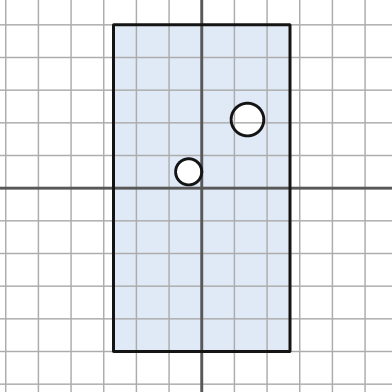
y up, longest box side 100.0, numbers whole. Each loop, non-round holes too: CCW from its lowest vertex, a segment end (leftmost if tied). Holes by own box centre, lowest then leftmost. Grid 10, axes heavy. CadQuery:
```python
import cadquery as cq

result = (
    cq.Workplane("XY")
    .moveTo(-27.0, -50.0)
    .lineTo(27.0, -50.0)
    .lineTo(27.0, 50.0)
    .lineTo(-27.0, 50.0)
    .close()
    .moveTo(-4.0, 5.0)
    .circle(4.0)
    .moveTo(14.0, 21.0)
    .circle(5.0)
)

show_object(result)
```